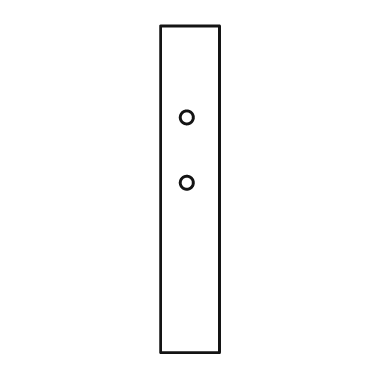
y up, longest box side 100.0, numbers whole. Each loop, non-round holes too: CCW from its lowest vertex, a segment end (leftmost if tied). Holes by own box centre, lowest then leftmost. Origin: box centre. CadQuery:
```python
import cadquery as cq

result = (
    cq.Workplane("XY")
    .moveTo(-9.0, -50.0)
    .lineTo(9.0, -50.0)
    .lineTo(9.0, 50.0)
    .lineTo(-9.0, 50.0)
    .close()
    .moveTo(-1.0, 2.0)
    .circle(2.0)
    .moveTo(-1.0, 22.0)
    .circle(2.0)
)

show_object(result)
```